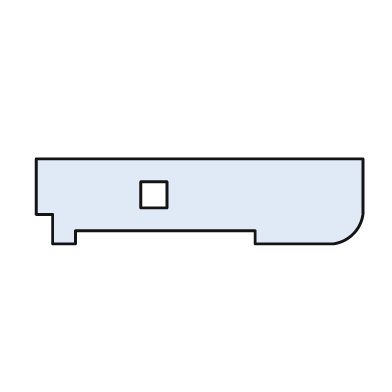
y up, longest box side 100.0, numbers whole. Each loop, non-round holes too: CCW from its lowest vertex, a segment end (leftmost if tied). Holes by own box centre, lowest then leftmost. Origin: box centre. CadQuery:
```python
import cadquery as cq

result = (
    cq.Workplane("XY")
    .moveTo(-45.0, -13.0)
    .lineTo(-38.0, -13.0)
    .lineTo(-38.0, -9.0)
    .lineTo(17.0, -9.0)
    .lineTo(17.0, -13.0)
    .lineTo(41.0, -13.0)
    .threePointArc((47.0, -10.0), (50.0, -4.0))
    .lineTo(50.0, 13.0)
    .lineTo(-50.0, 13.0)
    .lineTo(-50.0, -4.0)
    .lineTo(-45.0, -4.0)
    .close()
    .moveTo(-18.0, -2.0)
    .lineTo(-10.0, -2.0)
    .lineTo(-10.0, 6.0)
    .lineTo(-18.0, 6.0)
    .close()
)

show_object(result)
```